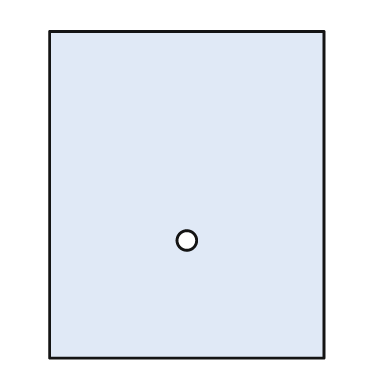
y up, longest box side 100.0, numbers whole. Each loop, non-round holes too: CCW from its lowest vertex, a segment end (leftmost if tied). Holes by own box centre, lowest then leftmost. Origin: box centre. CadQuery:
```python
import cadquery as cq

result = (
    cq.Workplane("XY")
    .moveTo(-42.0, -50.0)
    .lineTo(42.0, -50.0)
    .lineTo(42.0, 50.0)
    .lineTo(-42.0, 50.0)
    .close()
    .moveTo(0.0, -14.0)
    .circle(3.0)
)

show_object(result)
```